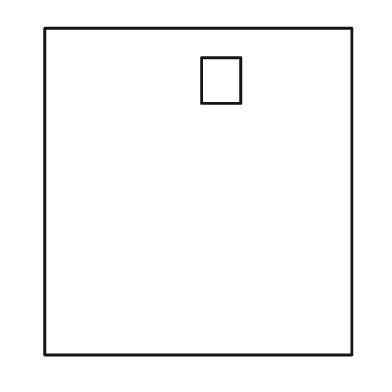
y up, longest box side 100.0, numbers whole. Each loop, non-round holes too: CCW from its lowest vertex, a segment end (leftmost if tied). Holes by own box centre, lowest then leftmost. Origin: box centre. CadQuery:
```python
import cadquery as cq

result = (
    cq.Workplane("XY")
    .moveTo(-47.0, -50.0)
    .lineTo(47.0, -50.0)
    .lineTo(47.0, 50.0)
    .lineTo(-47.0, 50.0)
    .close()
    .moveTo(1.0, 27.0)
    .lineTo(13.0, 27.0)
    .lineTo(13.0, 41.0)
    .lineTo(1.0, 41.0)
    .close()
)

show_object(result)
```